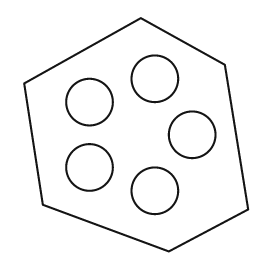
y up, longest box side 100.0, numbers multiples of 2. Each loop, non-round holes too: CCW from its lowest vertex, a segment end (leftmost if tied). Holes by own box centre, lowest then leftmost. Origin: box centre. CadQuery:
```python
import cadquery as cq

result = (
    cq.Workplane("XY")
    .moveTo(14.0, -50.0)
    .lineTo(48.0, -32.0)
    .lineTo(38.0, 30.0)
    .lineTo(2.0, 50.0)
    .lineTo(-48.0, 22.0)
    .lineTo(-40.0, -30.0)
    .close()
    .moveTo(8.0, -24.0)
    .circle(10.0)
    .moveTo(-20.0, -14.0)
    .circle(10.0)
    .moveTo(24.0, 0.0)
    .circle(10.0)
    .moveTo(-20.0, 14.0)
    .circle(10.0)
    .moveTo(8.0, 24.0)
    .circle(10.0)
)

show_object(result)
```